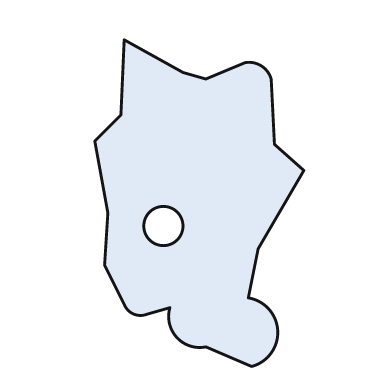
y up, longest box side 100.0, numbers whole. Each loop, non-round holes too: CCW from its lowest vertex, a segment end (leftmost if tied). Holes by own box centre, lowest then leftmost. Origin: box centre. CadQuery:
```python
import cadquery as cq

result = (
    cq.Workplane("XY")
    .moveTo(16.0, -50.0)
    .threePointArc((24.0, -39.0), (15.0, -29.0))
    .lineTo(18.0, -14.0)
    .lineTo(32.0, 10.0)
    .lineTo(23.0, 18.0)
    .lineTo(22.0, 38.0)
    .threePointArc((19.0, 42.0), (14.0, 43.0))
    .lineTo(2.0, 38.0)
    .lineTo(-5.0, 40.0)
    .lineTo(-23.0, 50.0)
    .lineTo(-24.0, 27.0)
    .lineTo(-32.0, 19.0)
    .lineTo(-28.0, -3.0)
    .lineTo(-29.0, -19.0)
    .lineTo(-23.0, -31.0)
    .threePointArc((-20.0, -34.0), (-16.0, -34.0))
    .lineTo(-9.0, -32.0)
    .threePointArc((-7.0, -41.0), (2.0, -44.0))
    .close()
    .moveTo(-11.0, -7.0)
    .circle(6.0)
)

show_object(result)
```